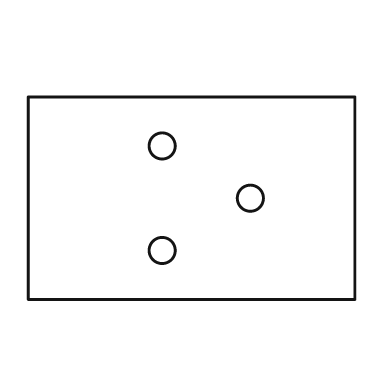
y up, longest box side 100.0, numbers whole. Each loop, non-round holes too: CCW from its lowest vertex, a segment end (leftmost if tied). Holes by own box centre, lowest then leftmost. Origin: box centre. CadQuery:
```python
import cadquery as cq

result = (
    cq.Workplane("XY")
    .moveTo(-50.0, -31.0)
    .lineTo(50.0, -31.0)
    .lineTo(50.0, 31.0)
    .lineTo(-50.0, 31.0)
    .close()
    .moveTo(-9.0, -16.0)
    .circle(4.0)
    .moveTo(18.0, 0.0)
    .circle(4.0)
    .moveTo(-9.0, 16.0)
    .circle(4.0)
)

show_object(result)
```